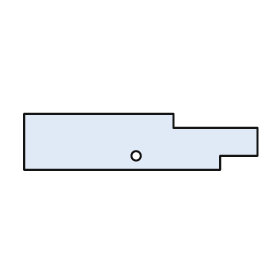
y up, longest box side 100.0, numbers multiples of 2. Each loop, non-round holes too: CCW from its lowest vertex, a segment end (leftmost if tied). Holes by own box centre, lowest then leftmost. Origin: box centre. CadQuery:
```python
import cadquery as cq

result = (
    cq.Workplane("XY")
    .moveTo(-50.0, -12.0)
    .lineTo(34.0, -12.0)
    .lineTo(34.0, -6.0)
    .lineTo(50.0, -6.0)
    .lineTo(50.0, 6.0)
    .lineTo(14.0, 6.0)
    .lineTo(14.0, 12.0)
    .lineTo(-50.0, 12.0)
    .close()
    .moveTo(-2.0, -6.0)
    .circle(2.0)
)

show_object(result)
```